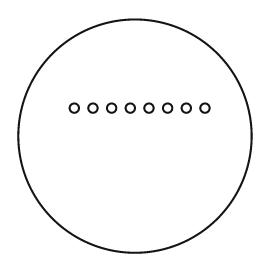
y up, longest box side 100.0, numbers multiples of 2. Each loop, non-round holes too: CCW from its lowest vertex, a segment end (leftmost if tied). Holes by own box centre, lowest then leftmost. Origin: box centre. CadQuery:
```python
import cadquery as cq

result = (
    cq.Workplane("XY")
    .moveTo(0.0, 0.0)
    .circle(50.0)
    .moveTo(-26.0, 12.0)
    .circle(2.0)
    .moveTo(-18.0, 12.0)
    .circle(2.0)
    .moveTo(-10.0, 12.0)
    .circle(2.0)
    .moveTo(-2.0, 12.0)
    .circle(2.0)
    .moveTo(6.0, 12.0)
    .circle(2.0)
    .moveTo(14.0, 12.0)
    .circle(2.0)
    .moveTo(22.0, 12.0)
    .circle(2.0)
    .moveTo(30.0, 12.0)
    .circle(2.0)
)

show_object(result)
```